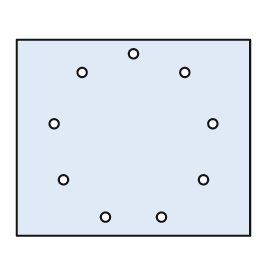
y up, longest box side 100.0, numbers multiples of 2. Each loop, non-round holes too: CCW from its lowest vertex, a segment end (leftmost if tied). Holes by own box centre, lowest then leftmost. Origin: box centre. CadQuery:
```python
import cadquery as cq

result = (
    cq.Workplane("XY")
    .moveTo(-50.0, -42.0)
    .lineTo(50.0, -42.0)
    .lineTo(50.0, 42.0)
    .lineTo(-50.0, 42.0)
    .close()
    .moveTo(-12.0, -34.0)
    .circle(2.0)
    .moveTo(12.0, -34.0)
    .circle(2.0)
    .moveTo(-30.0, -18.0)
    .circle(2.0)
    .moveTo(30.0, -18.0)
    .circle(2.0)
    .moveTo(-34.0, 6.0)
    .circle(2.0)
    .moveTo(34.0, 6.0)
    .circle(2.0)
    .moveTo(-22.0, 28.0)
    .circle(2.0)
    .moveTo(22.0, 28.0)
    .circle(2.0)
    .moveTo(0.0, 36.0)
    .circle(2.0)
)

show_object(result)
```